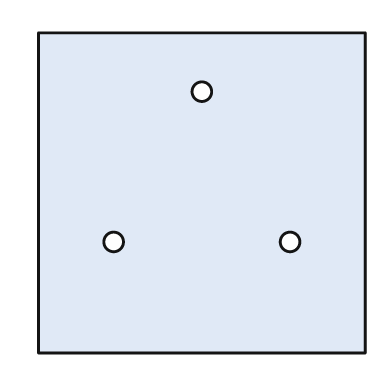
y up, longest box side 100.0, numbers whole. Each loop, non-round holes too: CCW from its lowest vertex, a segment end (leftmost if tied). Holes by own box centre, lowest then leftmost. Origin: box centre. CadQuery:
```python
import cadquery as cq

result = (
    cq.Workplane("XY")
    .moveTo(-50.0, -49.0)
    .lineTo(50.0, -49.0)
    .lineTo(50.0, 49.0)
    .lineTo(-50.0, 49.0)
    .close()
    .moveTo(-27.0, -15.0)
    .circle(3.0)
    .moveTo(27.0, -15.0)
    .circle(3.0)
    .moveTo(0.0, 31.0)
    .circle(3.0)
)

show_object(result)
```